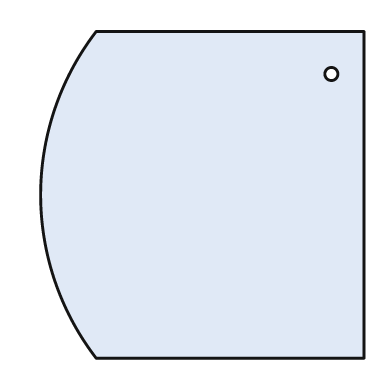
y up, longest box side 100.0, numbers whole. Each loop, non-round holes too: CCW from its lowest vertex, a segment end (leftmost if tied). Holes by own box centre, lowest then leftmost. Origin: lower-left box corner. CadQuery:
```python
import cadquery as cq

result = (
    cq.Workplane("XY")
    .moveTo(17.0, 0.0)
    .lineTo(99.0, 0.0)
    .lineTo(99.0, 100.0)
    .lineTo(17.0, 100.0)
    .threePointArc((0.0, 50.0), (17.0, 0.0))
    .close()
    .moveTo(89.0, 87.0)
    .circle(2.0)
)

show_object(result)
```